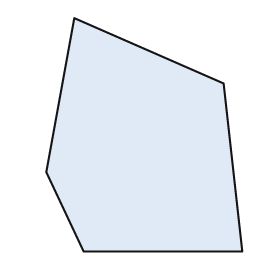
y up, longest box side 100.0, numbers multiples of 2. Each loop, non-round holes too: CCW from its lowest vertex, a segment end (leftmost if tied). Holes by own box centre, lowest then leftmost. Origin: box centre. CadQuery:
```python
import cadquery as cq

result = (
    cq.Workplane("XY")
    .moveTo(-26.0, -50.0)
    .lineTo(42.0, -50.0)
    .lineTo(34.0, 22.0)
    .lineTo(-30.0, 50.0)
    .lineTo(-42.0, -16.0)
    .close()
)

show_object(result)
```